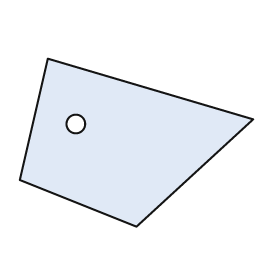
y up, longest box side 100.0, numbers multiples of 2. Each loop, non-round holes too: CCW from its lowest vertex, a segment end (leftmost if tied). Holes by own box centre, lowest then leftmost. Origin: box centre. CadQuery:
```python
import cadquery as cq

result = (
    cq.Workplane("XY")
    .moveTo(0.0, -36.0)
    .lineTo(50.0, 10.0)
    .lineTo(-38.0, 36.0)
    .lineTo(-50.0, -16.0)
    .close()
    .moveTo(-26.0, 8.0)
    .circle(4.0)
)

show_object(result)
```